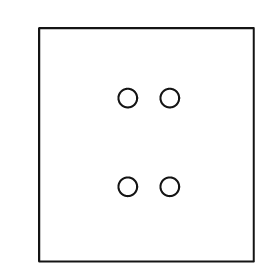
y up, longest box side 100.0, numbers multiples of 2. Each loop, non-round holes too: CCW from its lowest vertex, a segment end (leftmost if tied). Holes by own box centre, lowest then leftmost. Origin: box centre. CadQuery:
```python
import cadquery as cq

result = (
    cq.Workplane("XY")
    .moveTo(-46.0, -50.0)
    .lineTo(46.0, -50.0)
    .lineTo(46.0, 50.0)
    .lineTo(-46.0, 50.0)
    .close()
    .moveTo(-8.0, -18.0)
    .circle(4.0)
    .moveTo(10.0, -18.0)
    .circle(4.0)
    .moveTo(-8.0, 20.0)
    .circle(4.0)
    .moveTo(10.0, 20.0)
    .circle(4.0)
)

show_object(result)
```